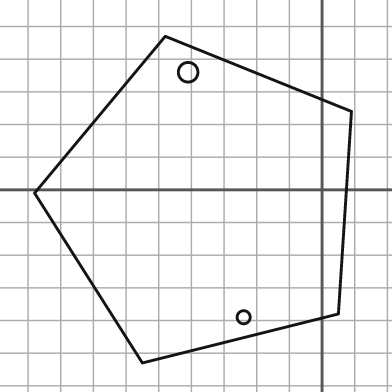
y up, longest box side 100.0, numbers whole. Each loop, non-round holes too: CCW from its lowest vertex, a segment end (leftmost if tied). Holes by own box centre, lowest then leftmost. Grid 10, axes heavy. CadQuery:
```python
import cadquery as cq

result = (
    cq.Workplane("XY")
    .moveTo(-55.0, -53.0)
    .lineTo(5.0, -38.0)
    .lineTo(9.0, 24.0)
    .lineTo(-48.0, 47.0)
    .lineTo(-88.0, -1.0)
    .close()
    .moveTo(-24.0, -39.0)
    .circle(2.0)
    .moveTo(-41.0, 36.0)
    .circle(3.0)
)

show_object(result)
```